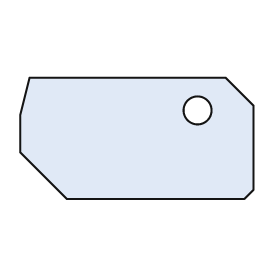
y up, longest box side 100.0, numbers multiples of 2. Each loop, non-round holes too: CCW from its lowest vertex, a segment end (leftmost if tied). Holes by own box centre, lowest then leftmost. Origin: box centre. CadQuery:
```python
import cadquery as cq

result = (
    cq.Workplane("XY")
    .moveTo(-30.0, -26.0)
    .lineTo(46.0, -26.0)
    .lineTo(50.0, -22.0)
    .lineTo(50.0, 14.0)
    .lineTo(38.0, 26.0)
    .lineTo(-46.0, 26.0)
    .lineTo(-50.0, 10.0)
    .lineTo(-50.0, -6.0)
    .close()
    .moveTo(26.0, 12.0)
    .circle(6.0)
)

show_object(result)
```